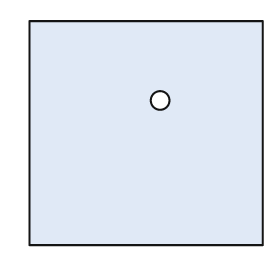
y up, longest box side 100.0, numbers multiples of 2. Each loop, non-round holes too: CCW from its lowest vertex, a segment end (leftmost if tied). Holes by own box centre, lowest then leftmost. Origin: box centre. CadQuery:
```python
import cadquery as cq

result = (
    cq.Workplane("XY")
    .moveTo(-50.0, -48.0)
    .lineTo(50.0, -48.0)
    .lineTo(50.0, 48.0)
    .lineTo(-50.0, 48.0)
    .close()
    .moveTo(6.0, 14.0)
    .circle(4.0)
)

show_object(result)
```